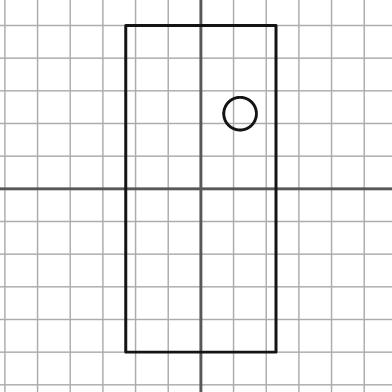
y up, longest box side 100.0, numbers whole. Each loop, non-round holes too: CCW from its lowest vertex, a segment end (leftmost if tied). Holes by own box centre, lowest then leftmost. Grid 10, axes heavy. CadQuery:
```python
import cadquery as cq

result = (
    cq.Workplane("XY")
    .moveTo(-23.0, -50.0)
    .lineTo(23.0, -50.0)
    .lineTo(23.0, 50.0)
    .lineTo(-23.0, 50.0)
    .close()
    .moveTo(12.0, 23.0)
    .circle(5.0)
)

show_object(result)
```